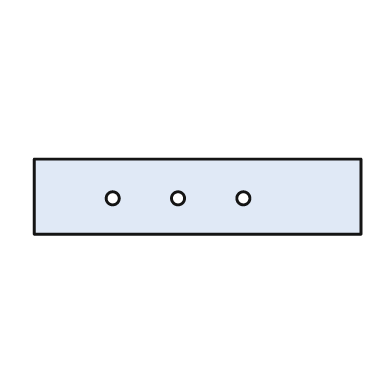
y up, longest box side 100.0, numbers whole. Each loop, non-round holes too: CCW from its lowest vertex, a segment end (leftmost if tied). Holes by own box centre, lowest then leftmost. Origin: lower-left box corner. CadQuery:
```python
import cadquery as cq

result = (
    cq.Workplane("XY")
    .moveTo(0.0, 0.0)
    .lineTo(100.0, 0.0)
    .lineTo(100.0, 23.0)
    .lineTo(0.0, 23.0)
    .close()
    .moveTo(24.0, 11.0)
    .circle(2.0)
    .moveTo(44.0, 11.0)
    .circle(2.0)
    .moveTo(64.0, 11.0)
    .circle(2.0)
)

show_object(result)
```